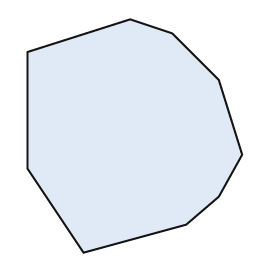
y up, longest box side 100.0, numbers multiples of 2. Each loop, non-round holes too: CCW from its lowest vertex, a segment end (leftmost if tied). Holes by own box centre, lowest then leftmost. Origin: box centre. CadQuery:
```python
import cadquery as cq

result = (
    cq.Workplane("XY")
    .moveTo(-22.0, -50.0)
    .lineTo(22.0, -38.0)
    .lineTo(36.0, -26.0)
    .lineTo(46.0, -8.0)
    .lineTo(36.0, 24.0)
    .lineTo(16.0, 44.0)
    .lineTo(-2.0, 50.0)
    .lineTo(-46.0, 36.0)
    .lineTo(-46.0, -14.0)
    .close()
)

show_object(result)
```